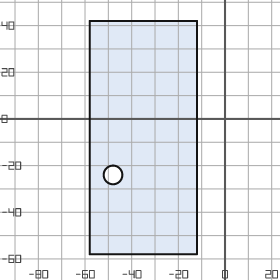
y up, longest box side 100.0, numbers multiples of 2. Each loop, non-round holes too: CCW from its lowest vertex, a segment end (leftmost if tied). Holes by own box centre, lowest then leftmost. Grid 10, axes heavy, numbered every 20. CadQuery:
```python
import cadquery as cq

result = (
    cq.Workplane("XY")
    .moveTo(-58.0, -58.0)
    .lineTo(-12.0, -58.0)
    .lineTo(-12.0, 42.0)
    .lineTo(-58.0, 42.0)
    .close()
    .moveTo(-48.0, -24.0)
    .circle(4.0)
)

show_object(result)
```